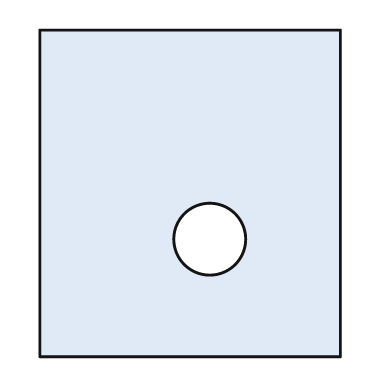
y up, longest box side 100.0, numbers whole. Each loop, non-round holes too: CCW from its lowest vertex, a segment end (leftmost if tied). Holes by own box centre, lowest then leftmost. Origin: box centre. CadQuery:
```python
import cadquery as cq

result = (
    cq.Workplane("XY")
    .moveTo(-46.0, -50.0)
    .lineTo(46.0, -50.0)
    .lineTo(46.0, 50.0)
    .lineTo(-46.0, 50.0)
    .close()
    .moveTo(6.0, -14.0)
    .circle(11.0)
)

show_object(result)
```